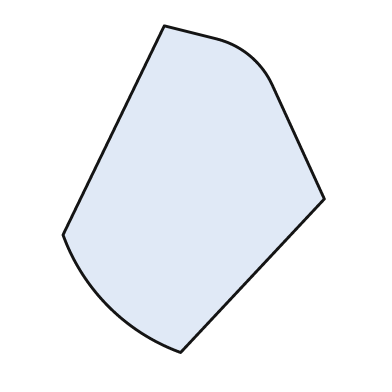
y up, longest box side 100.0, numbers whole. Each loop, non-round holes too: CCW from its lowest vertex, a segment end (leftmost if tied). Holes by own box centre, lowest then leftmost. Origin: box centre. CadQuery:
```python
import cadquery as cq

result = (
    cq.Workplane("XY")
    .moveTo(-4.0, -50.0)
    .lineTo(40.0, -3.0)
    .lineTo(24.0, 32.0)
    .threePointArc((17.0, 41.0), (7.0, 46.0))
    .lineTo(-9.0, 50.0)
    .lineTo(-40.0, -14.0)
    .threePointArc((-26.0, -36.0), (-4.0, -50.0))
    .close()
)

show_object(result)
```